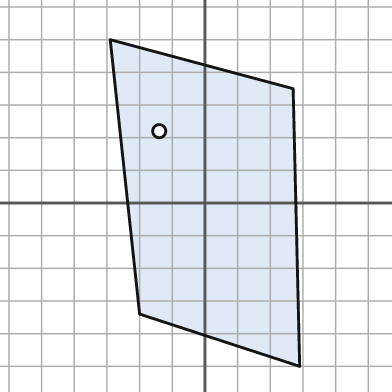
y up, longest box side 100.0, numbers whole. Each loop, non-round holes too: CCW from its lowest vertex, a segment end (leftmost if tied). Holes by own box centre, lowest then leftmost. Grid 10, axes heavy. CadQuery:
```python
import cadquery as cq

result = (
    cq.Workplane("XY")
    .moveTo(29.0, -50.0)
    .lineTo(27.0, 35.0)
    .lineTo(-29.0, 50.0)
    .lineTo(-20.0, -34.0)
    .close()
    .moveTo(-14.0, 22.0)
    .circle(2.0)
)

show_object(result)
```